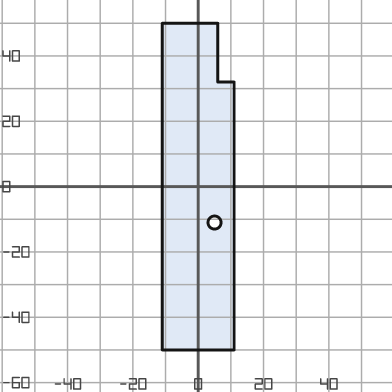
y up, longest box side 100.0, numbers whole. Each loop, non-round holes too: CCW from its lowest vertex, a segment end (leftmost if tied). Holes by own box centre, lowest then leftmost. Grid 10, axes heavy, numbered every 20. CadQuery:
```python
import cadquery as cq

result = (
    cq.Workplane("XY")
    .moveTo(-11.0, -50.0)
    .lineTo(11.0, -50.0)
    .lineTo(11.0, 32.0)
    .lineTo(6.0, 32.0)
    .lineTo(6.0, 50.0)
    .lineTo(-11.0, 50.0)
    .close()
    .moveTo(5.0, -11.0)
    .circle(2.0)
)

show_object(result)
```